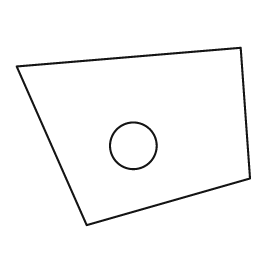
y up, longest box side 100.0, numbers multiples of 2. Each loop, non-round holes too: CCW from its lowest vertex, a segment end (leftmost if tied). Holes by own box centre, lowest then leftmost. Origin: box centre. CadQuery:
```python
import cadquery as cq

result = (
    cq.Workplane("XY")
    .moveTo(-20.0, -38.0)
    .lineTo(50.0, -18.0)
    .lineTo(46.0, 38.0)
    .lineTo(-50.0, 30.0)
    .close()
    .moveTo(0.0, -4.0)
    .circle(10.0)
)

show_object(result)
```